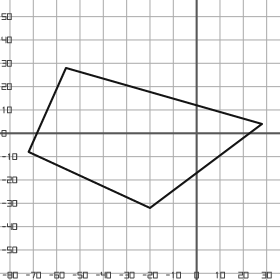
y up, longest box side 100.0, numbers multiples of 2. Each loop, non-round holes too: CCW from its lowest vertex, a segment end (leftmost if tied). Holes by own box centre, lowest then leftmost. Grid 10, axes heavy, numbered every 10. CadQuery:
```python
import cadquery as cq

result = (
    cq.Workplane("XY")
    .moveTo(-20.0, -32.0)
    .lineTo(28.0, 4.0)
    .lineTo(-56.0, 28.0)
    .lineTo(-72.0, -8.0)
    .close()
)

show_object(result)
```